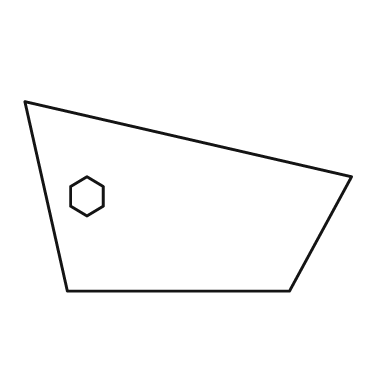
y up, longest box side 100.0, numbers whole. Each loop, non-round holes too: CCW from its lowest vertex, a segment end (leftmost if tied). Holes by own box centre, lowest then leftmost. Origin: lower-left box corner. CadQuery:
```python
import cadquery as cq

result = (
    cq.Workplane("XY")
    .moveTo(13.0, 0.0)
    .lineTo(81.0, 0.0)
    .lineTo(100.0, 35.0)
    .lineTo(0.0, 58.0)
    .close()
    .moveTo(19.0, 23.0)
    .lineTo(24.0, 26.0)
    .lineTo(24.0, 32.0)
    .lineTo(19.0, 35.0)
    .lineTo(14.0, 32.0)
    .lineTo(14.0, 26.0)
    .close()
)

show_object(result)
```